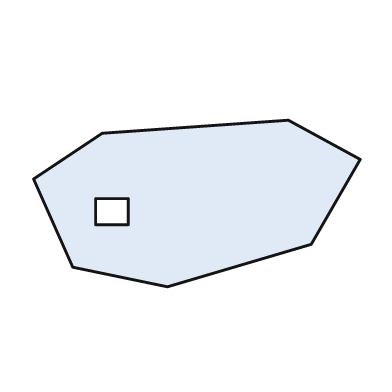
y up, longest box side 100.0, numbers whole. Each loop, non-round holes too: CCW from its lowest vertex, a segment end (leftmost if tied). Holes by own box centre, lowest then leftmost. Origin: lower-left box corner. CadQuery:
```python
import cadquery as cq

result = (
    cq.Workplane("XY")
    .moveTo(41.0, 0.0)
    .lineTo(85.0, 13.0)
    .lineTo(100.0, 39.0)
    .lineTo(78.0, 51.0)
    .lineTo(21.0, 47.0)
    .lineTo(0.0, 33.0)
    .lineTo(12.0, 6.0)
    .close()
    .moveTo(19.0, 19.0)
    .lineTo(29.0, 19.0)
    .lineTo(29.0, 27.0)
    .lineTo(19.0, 27.0)
    .close()
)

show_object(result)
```